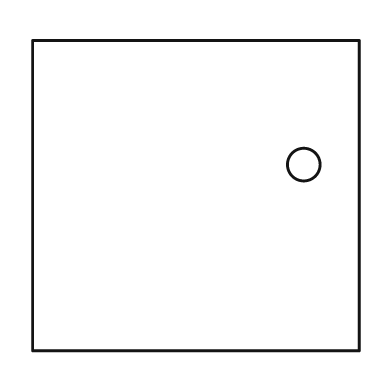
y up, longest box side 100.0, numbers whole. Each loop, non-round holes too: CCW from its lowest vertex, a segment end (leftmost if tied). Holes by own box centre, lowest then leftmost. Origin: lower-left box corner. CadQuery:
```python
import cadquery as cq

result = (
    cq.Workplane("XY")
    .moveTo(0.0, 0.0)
    .lineTo(100.0, 0.0)
    .lineTo(100.0, 95.0)
    .lineTo(0.0, 95.0)
    .close()
    .moveTo(83.0, 57.0)
    .circle(5.0)
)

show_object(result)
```